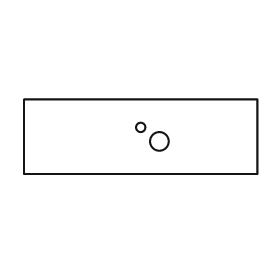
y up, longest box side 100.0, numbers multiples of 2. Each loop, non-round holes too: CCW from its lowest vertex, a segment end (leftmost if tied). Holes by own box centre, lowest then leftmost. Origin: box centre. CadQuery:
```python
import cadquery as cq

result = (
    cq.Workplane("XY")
    .moveTo(-50.0, -16.0)
    .lineTo(50.0, -16.0)
    .lineTo(50.0, 16.0)
    .lineTo(-50.0, 16.0)
    .close()
    .moveTo(8.0, -2.0)
    .circle(4.0)
    .moveTo(0.0, 4.0)
    .circle(2.0)
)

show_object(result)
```